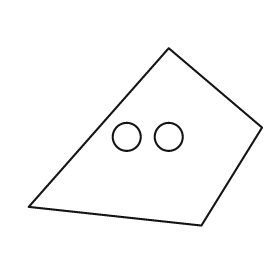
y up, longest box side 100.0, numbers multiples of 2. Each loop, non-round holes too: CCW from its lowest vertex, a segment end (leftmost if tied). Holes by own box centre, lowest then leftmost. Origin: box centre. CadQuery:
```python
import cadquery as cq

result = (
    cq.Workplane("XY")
    .moveTo(24.0, -38.0)
    .lineTo(50.0, 4.0)
    .lineTo(10.0, 38.0)
    .lineTo(-50.0, -30.0)
    .close()
    .moveTo(-8.0, 0.0)
    .circle(6.0)
    .moveTo(10.0, 0.0)
    .circle(6.0)
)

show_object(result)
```